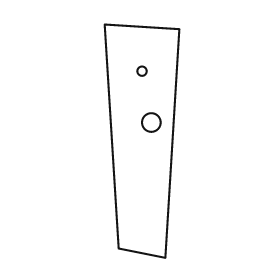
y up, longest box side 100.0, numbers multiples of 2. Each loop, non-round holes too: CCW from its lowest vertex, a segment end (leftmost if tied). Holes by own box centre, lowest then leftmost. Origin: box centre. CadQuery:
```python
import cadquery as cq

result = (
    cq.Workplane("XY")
    .moveTo(10.0, -50.0)
    .lineTo(16.0, 48.0)
    .lineTo(-16.0, 50.0)
    .lineTo(-10.0, -46.0)
    .close()
    .moveTo(4.0, 8.0)
    .circle(4.0)
    .moveTo(0.0, 30.0)
    .circle(2.0)
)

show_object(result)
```